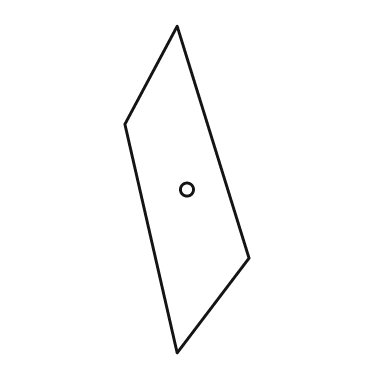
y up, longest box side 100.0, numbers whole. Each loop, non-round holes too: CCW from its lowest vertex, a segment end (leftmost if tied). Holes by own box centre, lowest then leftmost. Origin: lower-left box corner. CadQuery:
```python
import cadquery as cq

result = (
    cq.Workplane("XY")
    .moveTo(16.0, 0.0)
    .lineTo(38.0, 29.0)
    .lineTo(16.0, 100.0)
    .lineTo(0.0, 70.0)
    .close()
    .moveTo(19.0, 50.0)
    .circle(2.0)
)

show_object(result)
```